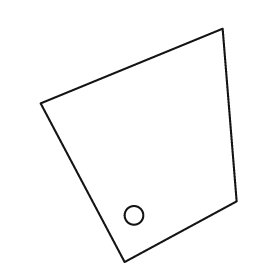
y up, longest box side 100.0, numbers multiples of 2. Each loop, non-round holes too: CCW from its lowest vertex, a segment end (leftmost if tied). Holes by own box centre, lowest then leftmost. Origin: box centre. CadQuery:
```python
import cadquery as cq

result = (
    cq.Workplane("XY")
    .moveTo(-6.0, -50.0)
    .lineTo(42.0, -24.0)
    .lineTo(36.0, 50.0)
    .lineTo(-42.0, 18.0)
    .close()
    .moveTo(-2.0, -30.0)
    .circle(4.0)
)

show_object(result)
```